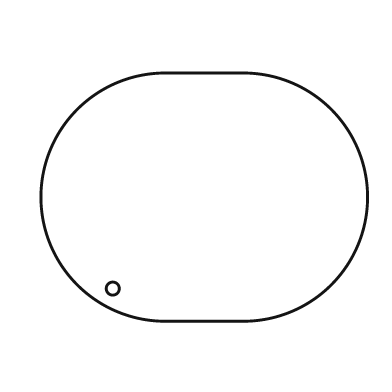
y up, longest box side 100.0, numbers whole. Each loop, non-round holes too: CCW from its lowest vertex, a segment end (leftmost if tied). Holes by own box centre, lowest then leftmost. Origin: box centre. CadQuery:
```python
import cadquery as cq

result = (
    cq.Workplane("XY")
    .moveTo(-12.0, -38.0)
    .lineTo(12.0, -38.0)
    .threePointArc((50.0, 0.0), (12.0, 38.0))
    .lineTo(-12.0, 38.0)
    .threePointArc((-50.0, 0.0), (-12.0, -38.0))
    .close()
    .moveTo(-28.0, -28.0)
    .circle(2.0)
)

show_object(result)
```